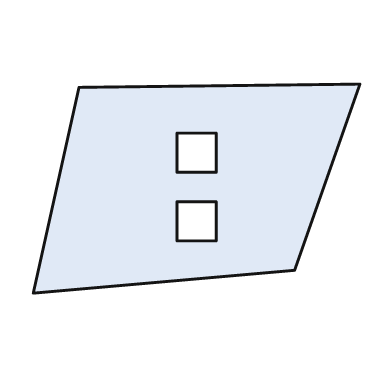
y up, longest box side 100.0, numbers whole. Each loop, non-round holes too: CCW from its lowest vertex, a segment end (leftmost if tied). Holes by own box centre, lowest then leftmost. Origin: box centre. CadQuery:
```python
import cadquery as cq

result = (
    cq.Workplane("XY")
    .moveTo(-50.0, -32.0)
    .lineTo(30.0, -25.0)
    .lineTo(50.0, 32.0)
    .lineTo(-36.0, 31.0)
    .close()
    .moveTo(-6.0, -16.0)
    .lineTo(6.0, -16.0)
    .lineTo(6.0, -4.0)
    .lineTo(-6.0, -4.0)
    .close()
    .moveTo(-6.0, 5.0)
    .lineTo(6.0, 5.0)
    .lineTo(6.0, 17.0)
    .lineTo(-6.0, 17.0)
    .close()
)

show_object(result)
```